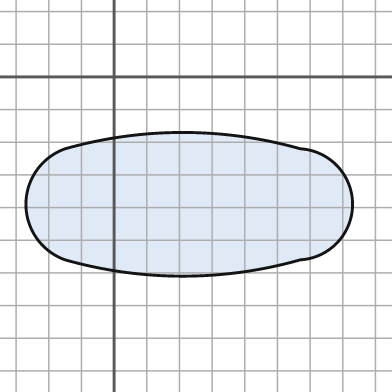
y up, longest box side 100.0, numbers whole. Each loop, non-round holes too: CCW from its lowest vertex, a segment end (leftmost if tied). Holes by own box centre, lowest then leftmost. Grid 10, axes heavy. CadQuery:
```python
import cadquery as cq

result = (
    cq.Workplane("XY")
    .moveTo(-15.0, -56.0)
    .threePointArc((21.0, -61.0), (57.0, -56.0))
    .threePointArc((73.0, -39.0), (57.0, -22.0))
    .threePointArc((21.0, -17.0), (-15.0, -22.0))
    .threePointArc((-27.0, -39.0), (-15.0, -56.0))
    .close()
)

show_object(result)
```